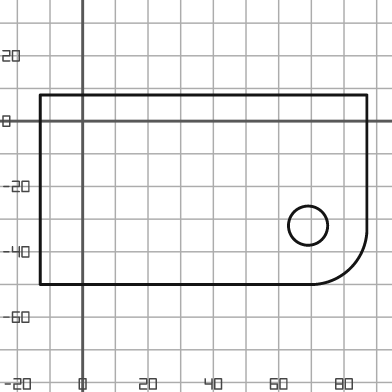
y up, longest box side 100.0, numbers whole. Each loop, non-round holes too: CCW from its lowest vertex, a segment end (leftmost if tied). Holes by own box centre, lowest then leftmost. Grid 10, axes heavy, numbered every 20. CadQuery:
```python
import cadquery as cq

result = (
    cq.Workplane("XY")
    .moveTo(-13.0, -50.0)
    .lineTo(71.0, -50.0)
    .threePointArc((82.0, -45.0), (87.0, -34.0))
    .lineTo(87.0, 8.0)
    .lineTo(-13.0, 8.0)
    .close()
    .moveTo(69.0, -32.0)
    .circle(6.0)
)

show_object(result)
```